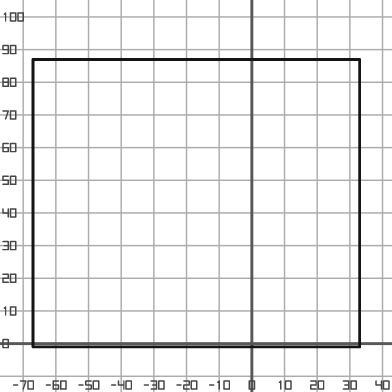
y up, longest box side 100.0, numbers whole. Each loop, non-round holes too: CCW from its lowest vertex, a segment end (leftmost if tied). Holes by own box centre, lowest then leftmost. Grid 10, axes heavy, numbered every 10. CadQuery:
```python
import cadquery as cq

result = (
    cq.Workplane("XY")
    .moveTo(-67.0, -1.0)
    .lineTo(33.0, -1.0)
    .lineTo(33.0, 87.0)
    .lineTo(-67.0, 87.0)
    .close()
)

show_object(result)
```